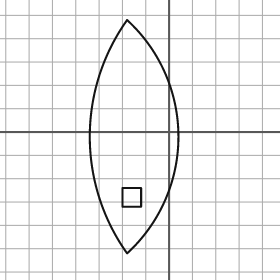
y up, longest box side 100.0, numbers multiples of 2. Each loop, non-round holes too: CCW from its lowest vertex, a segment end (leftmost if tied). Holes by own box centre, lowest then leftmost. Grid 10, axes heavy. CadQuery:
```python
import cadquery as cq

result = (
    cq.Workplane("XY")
    .moveTo(-18.0, -52.0)
    .threePointArc((4.0, -2.0), (-18.0, 48.0))
    .threePointArc((-34.0, -2.0), (-18.0, -52.0))
    .close()
    .moveTo(-20.0, -32.0)
    .lineTo(-12.0, -32.0)
    .lineTo(-12.0, -24.0)
    .lineTo(-20.0, -24.0)
    .close()
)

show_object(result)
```